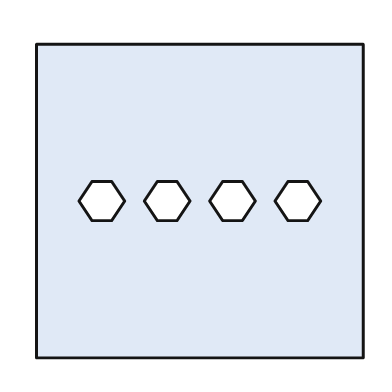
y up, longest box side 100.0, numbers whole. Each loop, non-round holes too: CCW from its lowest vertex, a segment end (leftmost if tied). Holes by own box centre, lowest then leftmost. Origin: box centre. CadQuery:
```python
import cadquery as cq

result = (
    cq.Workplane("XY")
    .moveTo(-50.0, -48.0)
    .lineTo(50.0, -48.0)
    .lineTo(50.0, 48.0)
    .lineTo(-50.0, 48.0)
    .close()
    .moveTo(-33.0, -6.0)
    .lineTo(-27.0, -6.0)
    .lineTo(-23.0, 0.0)
    .lineTo(-27.0, 6.0)
    .lineTo(-33.0, 6.0)
    .lineTo(-37.0, 0.0)
    .close()
    .moveTo(-13.0, -6.0)
    .lineTo(-7.0, -6.0)
    .lineTo(-3.0, 0.0)
    .lineTo(-7.0, 6.0)
    .lineTo(-13.0, 6.0)
    .lineTo(-17.0, 0.0)
    .close()
    .moveTo(7.0, -6.0)
    .lineTo(13.0, -6.0)
    .lineTo(17.0, 0.0)
    .lineTo(13.0, 6.0)
    .lineTo(7.0, 6.0)
    .lineTo(3.0, 0.0)
    .close()
    .moveTo(27.0, -6.0)
    .lineTo(33.0, -6.0)
    .lineTo(37.0, 0.0)
    .lineTo(33.0, 6.0)
    .lineTo(27.0, 6.0)
    .lineTo(23.0, 0.0)
    .close()
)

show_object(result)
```